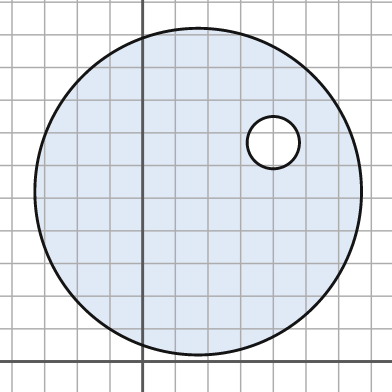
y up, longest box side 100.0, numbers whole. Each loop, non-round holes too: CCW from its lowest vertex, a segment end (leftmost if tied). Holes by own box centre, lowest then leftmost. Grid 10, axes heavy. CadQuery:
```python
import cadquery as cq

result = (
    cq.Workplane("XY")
    .moveTo(17.0, 52.0)
    .circle(50.0)
    .moveTo(40.0, 67.0)
    .circle(8.0)
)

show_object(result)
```